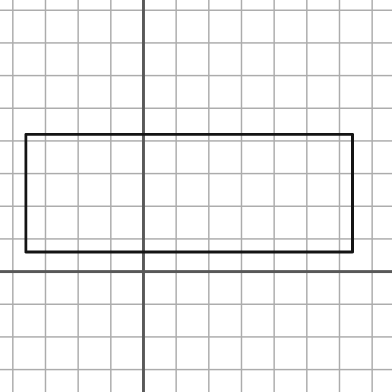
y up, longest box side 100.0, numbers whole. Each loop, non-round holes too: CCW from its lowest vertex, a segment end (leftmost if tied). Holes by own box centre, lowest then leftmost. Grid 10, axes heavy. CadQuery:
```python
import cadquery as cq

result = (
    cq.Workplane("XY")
    .moveTo(-36.0, 6.0)
    .lineTo(64.0, 6.0)
    .lineTo(64.0, 42.0)
    .lineTo(-36.0, 42.0)
    .close()
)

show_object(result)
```